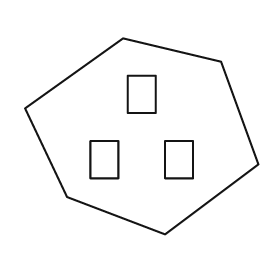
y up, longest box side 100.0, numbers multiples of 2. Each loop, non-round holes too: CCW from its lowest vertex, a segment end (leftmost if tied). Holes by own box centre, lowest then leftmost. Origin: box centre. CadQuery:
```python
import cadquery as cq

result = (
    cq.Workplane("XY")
    .moveTo(10.0, -42.0)
    .lineTo(50.0, -12.0)
    .lineTo(34.0, 32.0)
    .lineTo(-8.0, 42.0)
    .lineTo(-50.0, 12.0)
    .lineTo(-32.0, -26.0)
    .close()
    .moveTo(-22.0, -18.0)
    .lineTo(-10.0, -18.0)
    .lineTo(-10.0, -2.0)
    .lineTo(-22.0, -2.0)
    .close()
    .moveTo(10.0, -18.0)
    .lineTo(22.0, -18.0)
    .lineTo(22.0, -2.0)
    .lineTo(10.0, -2.0)
    .close()
    .moveTo(-6.0, 10.0)
    .lineTo(6.0, 10.0)
    .lineTo(6.0, 26.0)
    .lineTo(-6.0, 26.0)
    .close()
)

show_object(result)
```